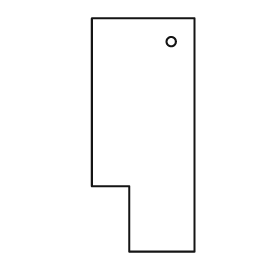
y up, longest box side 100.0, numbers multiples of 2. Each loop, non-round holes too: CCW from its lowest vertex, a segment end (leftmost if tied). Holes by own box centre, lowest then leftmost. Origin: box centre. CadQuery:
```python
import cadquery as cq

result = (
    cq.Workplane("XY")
    .moveTo(-6.0, -50.0)
    .lineTo(22.0, -50.0)
    .lineTo(22.0, 50.0)
    .lineTo(-22.0, 50.0)
    .lineTo(-22.0, -22.0)
    .lineTo(-6.0, -22.0)
    .close()
    .moveTo(12.0, 40.0)
    .circle(2.0)
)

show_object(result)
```